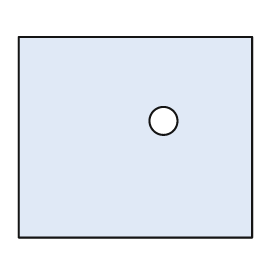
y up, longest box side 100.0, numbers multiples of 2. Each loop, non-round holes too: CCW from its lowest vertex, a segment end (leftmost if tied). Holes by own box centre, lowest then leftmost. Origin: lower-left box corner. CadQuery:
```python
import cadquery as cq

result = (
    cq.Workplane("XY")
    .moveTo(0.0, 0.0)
    .lineTo(100.0, 0.0)
    .lineTo(100.0, 86.0)
    .lineTo(0.0, 86.0)
    .close()
    .moveTo(62.0, 50.0)
    .circle(6.0)
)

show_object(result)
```